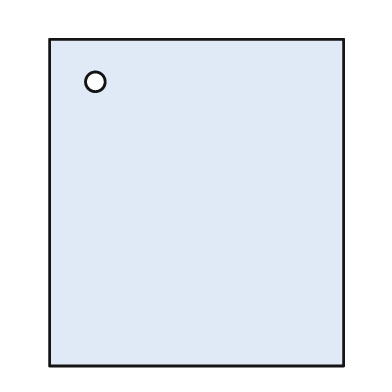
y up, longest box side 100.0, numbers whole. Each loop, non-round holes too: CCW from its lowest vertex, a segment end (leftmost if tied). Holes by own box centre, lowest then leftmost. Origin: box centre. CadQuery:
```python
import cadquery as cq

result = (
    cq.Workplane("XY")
    .moveTo(-45.0, -50.0)
    .lineTo(45.0, -50.0)
    .lineTo(45.0, 50.0)
    .lineTo(-45.0, 50.0)
    .close()
    .moveTo(-31.0, 37.0)
    .circle(3.0)
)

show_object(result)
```